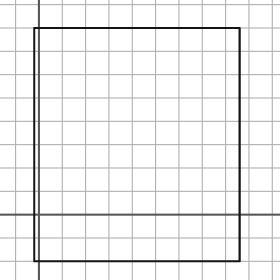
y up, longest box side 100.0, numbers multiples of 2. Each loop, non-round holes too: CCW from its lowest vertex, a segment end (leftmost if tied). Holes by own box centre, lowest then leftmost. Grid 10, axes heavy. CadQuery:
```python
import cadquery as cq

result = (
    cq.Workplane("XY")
    .moveTo(-2.0, -20.0)
    .lineTo(86.0, -20.0)
    .lineTo(86.0, 80.0)
    .lineTo(-2.0, 80.0)
    .close()
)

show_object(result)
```